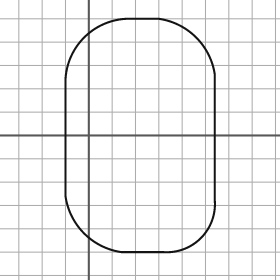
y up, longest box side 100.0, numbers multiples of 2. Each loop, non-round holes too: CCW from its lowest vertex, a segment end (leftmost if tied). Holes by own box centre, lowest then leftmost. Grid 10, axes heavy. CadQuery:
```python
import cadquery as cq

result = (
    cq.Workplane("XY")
    .moveTo(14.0, -50.0)
    .lineTo(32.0, -50.0)
    .threePointArc((48.0, -44.0), (54.0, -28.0))
    .lineTo(54.0, 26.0)
    .threePointArc((46.0, 42.0), (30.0, 50.0))
    .lineTo(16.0, 50.0)
    .threePointArc((-2.0, 42.0), (-10.0, 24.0))
    .lineTo(-10.0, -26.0)
    .threePointArc((-2.0, -42.0), (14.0, -50.0))
    .close()
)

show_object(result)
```